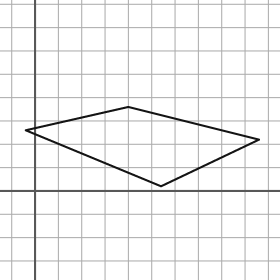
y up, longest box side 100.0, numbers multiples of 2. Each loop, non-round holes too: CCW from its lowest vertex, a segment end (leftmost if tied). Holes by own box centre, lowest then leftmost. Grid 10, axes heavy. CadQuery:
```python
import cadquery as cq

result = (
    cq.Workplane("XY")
    .moveTo(54.0, 2.0)
    .lineTo(96.0, 22.0)
    .lineTo(40.0, 36.0)
    .lineTo(-4.0, 26.0)
    .close()
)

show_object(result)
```